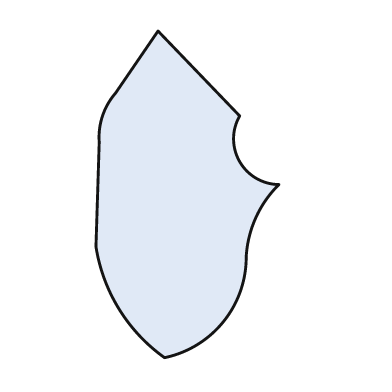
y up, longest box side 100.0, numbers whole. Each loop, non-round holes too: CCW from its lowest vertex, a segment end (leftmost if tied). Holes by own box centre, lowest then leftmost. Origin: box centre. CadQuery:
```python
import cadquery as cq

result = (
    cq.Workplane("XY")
    .moveTo(-7.0, -50.0)
    .threePointArc((11.0, -39.0), (18.0, -19.0))
    .threePointArc((21.0, -7.0), (28.0, 3.0))
    .threePointArc((16.0, 10.0), (16.0, 24.0))
    .lineTo(-9.0, 50.0)
    .lineTo(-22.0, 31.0)
    .threePointArc((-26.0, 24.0), (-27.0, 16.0))
    .lineTo(-28.0, -16.0)
    .threePointArc((-21.0, -35.0), (-7.0, -50.0))
    .close()
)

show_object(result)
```